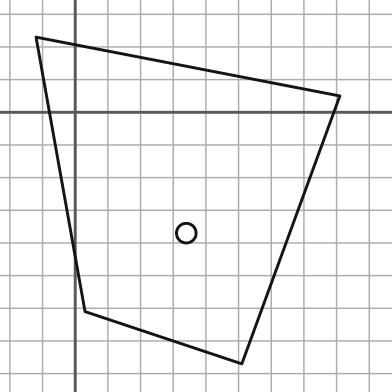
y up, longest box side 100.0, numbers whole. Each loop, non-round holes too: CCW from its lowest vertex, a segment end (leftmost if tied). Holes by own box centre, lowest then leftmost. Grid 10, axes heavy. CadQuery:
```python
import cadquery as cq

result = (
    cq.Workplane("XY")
    .moveTo(51.0, -77.0)
    .lineTo(81.0, 5.0)
    .lineTo(-12.0, 23.0)
    .lineTo(3.0, -61.0)
    .close()
    .moveTo(34.0, -37.0)
    .circle(3.0)
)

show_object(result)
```